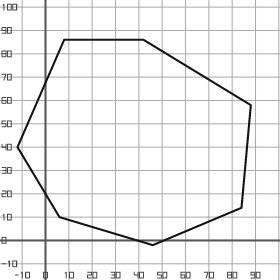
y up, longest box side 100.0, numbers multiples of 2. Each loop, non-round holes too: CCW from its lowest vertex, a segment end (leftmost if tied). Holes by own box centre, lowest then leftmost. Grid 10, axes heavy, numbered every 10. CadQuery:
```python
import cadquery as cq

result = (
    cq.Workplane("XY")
    .moveTo(46.0, -2.0)
    .lineTo(84.0, 14.0)
    .lineTo(88.0, 58.0)
    .lineTo(42.0, 86.0)
    .lineTo(8.0, 86.0)
    .lineTo(-12.0, 40.0)
    .lineTo(6.0, 10.0)
    .close()
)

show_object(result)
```